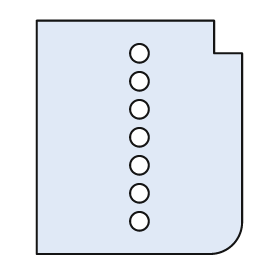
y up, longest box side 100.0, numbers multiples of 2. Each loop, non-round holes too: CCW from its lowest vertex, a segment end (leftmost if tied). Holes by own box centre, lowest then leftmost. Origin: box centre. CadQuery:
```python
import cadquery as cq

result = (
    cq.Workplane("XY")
    .moveTo(-44.0, -50.0)
    .lineTo(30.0, -50.0)
    .threePointArc((40.0, -46.0), (44.0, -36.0))
    .lineTo(44.0, 36.0)
    .lineTo(32.0, 36.0)
    .lineTo(32.0, 50.0)
    .lineTo(-44.0, 50.0)
    .close()
    .moveTo(0.0, -36.0)
    .circle(4.0)
    .moveTo(0.0, -24.0)
    .circle(4.0)
    .moveTo(0.0, -12.0)
    .circle(4.0)
    .moveTo(0.0, 0.0)
    .circle(4.0)
    .moveTo(0.0, 12.0)
    .circle(4.0)
    .moveTo(0.0, 24.0)
    .circle(4.0)
    .moveTo(0.0, 36.0)
    .circle(4.0)
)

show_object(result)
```